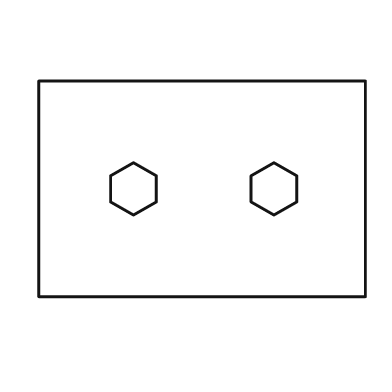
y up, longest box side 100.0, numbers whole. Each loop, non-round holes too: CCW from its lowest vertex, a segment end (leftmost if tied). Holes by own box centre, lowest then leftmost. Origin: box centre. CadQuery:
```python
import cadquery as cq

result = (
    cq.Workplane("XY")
    .moveTo(-50.0, -33.0)
    .lineTo(50.0, -33.0)
    .lineTo(50.0, 33.0)
    .lineTo(-50.0, 33.0)
    .close()
    .moveTo(-21.0, -8.0)
    .lineTo(-14.0, -4.0)
    .lineTo(-14.0, 4.0)
    .lineTo(-21.0, 8.0)
    .lineTo(-28.0, 4.0)
    .lineTo(-28.0, -4.0)
    .close()
    .moveTo(22.0, -8.0)
    .lineTo(29.0, -4.0)
    .lineTo(29.0, 4.0)
    .lineTo(22.0, 8.0)
    .lineTo(15.0, 4.0)
    .lineTo(15.0, -4.0)
    .close()
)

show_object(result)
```